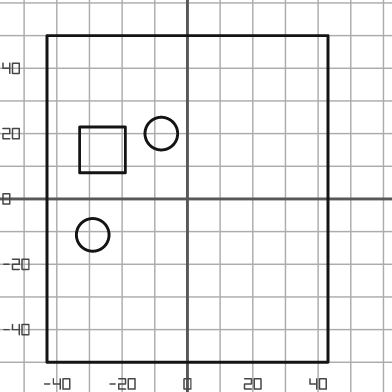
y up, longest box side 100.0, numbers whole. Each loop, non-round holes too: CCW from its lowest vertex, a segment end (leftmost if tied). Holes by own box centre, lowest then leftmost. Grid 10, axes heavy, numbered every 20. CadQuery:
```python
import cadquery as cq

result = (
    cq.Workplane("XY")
    .moveTo(-43.0, -50.0)
    .lineTo(43.0, -50.0)
    .lineTo(43.0, 50.0)
    .lineTo(-43.0, 50.0)
    .close()
    .moveTo(-29.0, -11.0)
    .circle(5.0)
    .moveTo(-33.0, 8.0)
    .lineTo(-19.0, 8.0)
    .lineTo(-19.0, 22.0)
    .lineTo(-33.0, 22.0)
    .close()
    .moveTo(-8.0, 20.0)
    .circle(5.0)
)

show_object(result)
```